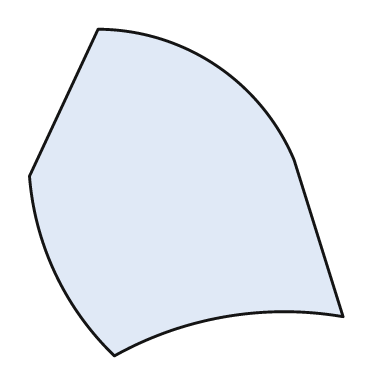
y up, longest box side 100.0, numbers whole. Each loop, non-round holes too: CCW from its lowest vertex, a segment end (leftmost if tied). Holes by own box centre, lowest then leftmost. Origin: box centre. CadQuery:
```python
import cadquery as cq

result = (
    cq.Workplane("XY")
    .moveTo(-22.0, -50.0)
    .threePointArc((12.0, -38.0), (48.0, -38.0))
    .lineTo(33.0, 10.0)
    .threePointArc((9.0, 39.0), (-27.0, 50.0))
    .lineTo(-48.0, 5.0)
    .threePointArc((-40.0, -25.0), (-22.0, -50.0))
    .close()
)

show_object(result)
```